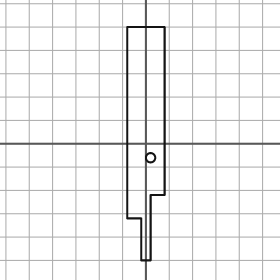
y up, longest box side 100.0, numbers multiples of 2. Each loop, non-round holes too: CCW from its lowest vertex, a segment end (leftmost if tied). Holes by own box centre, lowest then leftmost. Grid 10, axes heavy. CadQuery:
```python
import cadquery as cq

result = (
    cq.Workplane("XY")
    .moveTo(-2.0, -50.0)
    .lineTo(2.0, -50.0)
    .lineTo(2.0, -22.0)
    .lineTo(8.0, -22.0)
    .lineTo(8.0, 50.0)
    .lineTo(-8.0, 50.0)
    .lineTo(-8.0, -32.0)
    .lineTo(-2.0, -32.0)
    .close()
    .moveTo(2.0, -6.0)
    .circle(2.0)
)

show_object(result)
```